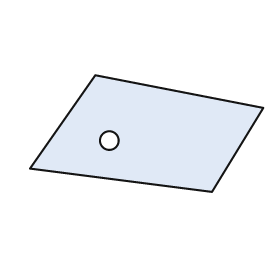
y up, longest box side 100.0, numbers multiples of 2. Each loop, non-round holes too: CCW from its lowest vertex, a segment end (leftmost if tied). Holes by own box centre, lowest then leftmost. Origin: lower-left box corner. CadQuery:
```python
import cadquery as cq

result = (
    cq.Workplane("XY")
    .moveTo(78.0, 0.0)
    .lineTo(100.0, 36.0)
    .lineTo(28.0, 50.0)
    .lineTo(0.0, 10.0)
    .close()
    .moveTo(34.0, 22.0)
    .circle(4.0)
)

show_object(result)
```